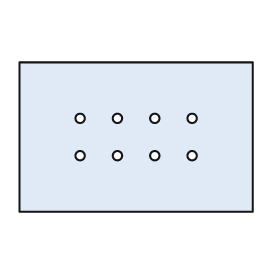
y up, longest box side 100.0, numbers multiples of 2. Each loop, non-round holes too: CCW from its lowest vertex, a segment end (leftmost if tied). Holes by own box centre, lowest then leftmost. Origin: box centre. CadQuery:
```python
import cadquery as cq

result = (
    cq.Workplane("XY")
    .moveTo(-50.0, -32.0)
    .lineTo(50.0, -32.0)
    .lineTo(50.0, 32.0)
    .lineTo(-50.0, 32.0)
    .close()
    .moveTo(-24.0, -8.0)
    .circle(2.0)
    .moveTo(-8.0, -8.0)
    .circle(2.0)
    .moveTo(8.0, -8.0)
    .circle(2.0)
    .moveTo(24.0, -8.0)
    .circle(2.0)
    .moveTo(-24.0, 8.0)
    .circle(2.0)
    .moveTo(-8.0, 8.0)
    .circle(2.0)
    .moveTo(8.0, 8.0)
    .circle(2.0)
    .moveTo(24.0, 8.0)
    .circle(2.0)
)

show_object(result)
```